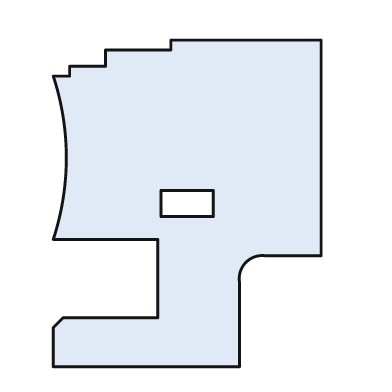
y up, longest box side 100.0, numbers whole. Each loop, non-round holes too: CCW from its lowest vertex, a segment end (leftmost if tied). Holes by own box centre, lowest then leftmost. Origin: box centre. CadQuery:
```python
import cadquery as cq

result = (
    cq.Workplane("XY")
    .moveTo(-41.0, -50.0)
    .lineTo(16.0, -50.0)
    .lineTo(16.0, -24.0)
    .threePointArc((18.0, -18.0), (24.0, -16.0))
    .lineTo(41.0, -16.0)
    .lineTo(41.0, 50.0)
    .lineTo(-5.0, 50.0)
    .lineTo(-5.0, 47.0)
    .lineTo(-25.0, 47.0)
    .lineTo(-25.0, 42.0)
    .lineTo(-36.0, 42.0)
    .lineTo(-36.0, 39.0)
    .lineTo(-41.0, 39.0)
    .threePointArc((-37.0, 14.0), (-41.0, -11.0))
    .lineTo(-9.0, -11.0)
    .lineTo(-9.0, -35.0)
    .lineTo(-38.0, -35.0)
    .lineTo(-41.0, -38.0)
    .close()
    .moveTo(-8.0, -4.0)
    .lineTo(8.0, -4.0)
    .lineTo(8.0, 4.0)
    .lineTo(-8.0, 4.0)
    .close()
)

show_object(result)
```